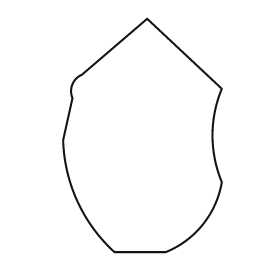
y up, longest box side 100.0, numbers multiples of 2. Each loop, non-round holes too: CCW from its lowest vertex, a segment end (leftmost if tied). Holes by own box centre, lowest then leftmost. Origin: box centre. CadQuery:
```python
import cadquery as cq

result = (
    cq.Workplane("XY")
    .moveTo(-12.0, -50.0)
    .lineTo(10.0, -50.0)
    .threePointArc((26.0, -38.0), (34.0, -20.0))
    .threePointArc((30.0, 0.0), (34.0, 20.0))
    .lineTo(2.0, 50.0)
    .lineTo(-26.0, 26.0)
    .threePointArc((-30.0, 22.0), (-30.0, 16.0))
    .lineTo(-34.0, -2.0)
    .threePointArc((-28.0, -28.0), (-12.0, -50.0))
    .close()
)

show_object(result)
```